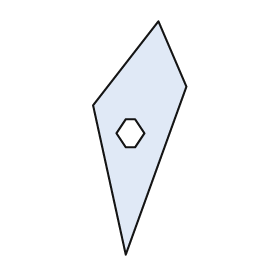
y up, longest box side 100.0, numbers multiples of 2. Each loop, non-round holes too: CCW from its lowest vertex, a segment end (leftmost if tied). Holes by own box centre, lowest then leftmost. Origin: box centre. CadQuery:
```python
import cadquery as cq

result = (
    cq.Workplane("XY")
    .moveTo(-6.0, -50.0)
    .lineTo(20.0, 22.0)
    .lineTo(8.0, 50.0)
    .lineTo(-20.0, 14.0)
    .close()
    .moveTo(-6.0, -4.0)
    .lineTo(-2.0, -4.0)
    .lineTo(2.0, 2.0)
    .lineTo(-2.0, 8.0)
    .lineTo(-6.0, 8.0)
    .lineTo(-10.0, 2.0)
    .close()
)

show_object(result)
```